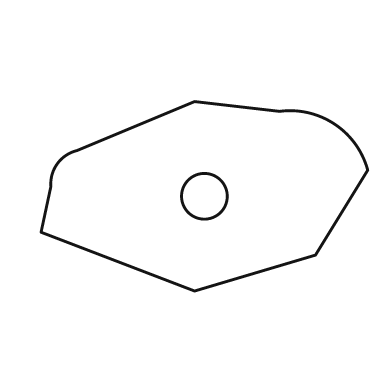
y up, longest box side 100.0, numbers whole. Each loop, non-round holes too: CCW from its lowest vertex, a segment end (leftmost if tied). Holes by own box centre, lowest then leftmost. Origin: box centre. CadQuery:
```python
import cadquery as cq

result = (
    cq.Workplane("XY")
    .moveTo(-3.0, -29.0)
    .lineTo(34.0, -18.0)
    .lineTo(50.0, 8.0)
    .threePointArc((40.0, 22.0), (23.0, 26.0))
    .lineTo(-3.0, 29.0)
    .lineTo(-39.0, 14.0)
    .threePointArc((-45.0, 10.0), (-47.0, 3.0))
    .lineTo(-50.0, -11.0)
    .close()
    .moveTo(0.0, 0.0)
    .circle(7.0)
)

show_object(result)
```